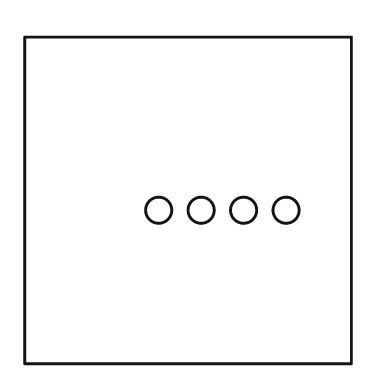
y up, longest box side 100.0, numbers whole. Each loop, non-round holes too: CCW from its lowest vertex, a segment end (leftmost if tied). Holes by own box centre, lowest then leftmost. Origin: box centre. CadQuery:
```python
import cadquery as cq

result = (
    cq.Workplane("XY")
    .moveTo(-50.0, -50.0)
    .lineTo(50.0, -50.0)
    .lineTo(50.0, 50.0)
    .lineTo(-50.0, 50.0)
    .close()
    .moveTo(-9.0, -3.0)
    .circle(4.0)
    .moveTo(4.0, -3.0)
    .circle(4.0)
    .moveTo(17.0, -3.0)
    .circle(4.0)
    .moveTo(30.0, -3.0)
    .circle(4.0)
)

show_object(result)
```